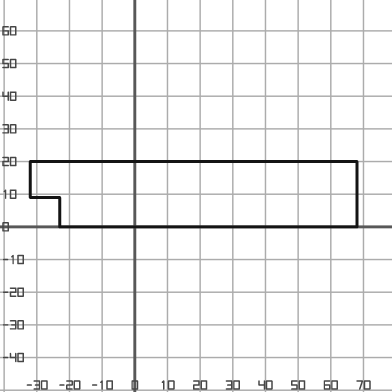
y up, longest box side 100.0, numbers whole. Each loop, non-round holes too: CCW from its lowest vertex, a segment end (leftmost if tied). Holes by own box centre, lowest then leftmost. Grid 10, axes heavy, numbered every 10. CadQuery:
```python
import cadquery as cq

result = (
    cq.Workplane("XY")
    .moveTo(-23.0, 0.0)
    .lineTo(68.0, 0.0)
    .lineTo(68.0, 20.0)
    .lineTo(-32.0, 20.0)
    .lineTo(-32.0, 9.0)
    .lineTo(-23.0, 9.0)
    .close()
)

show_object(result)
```